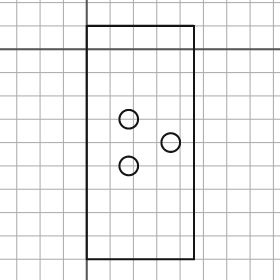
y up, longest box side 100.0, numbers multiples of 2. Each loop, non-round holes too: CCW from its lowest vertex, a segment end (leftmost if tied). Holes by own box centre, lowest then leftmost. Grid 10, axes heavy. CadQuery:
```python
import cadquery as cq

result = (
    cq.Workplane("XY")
    .moveTo(0.0, -90.0)
    .lineTo(46.0, -90.0)
    .lineTo(46.0, 10.0)
    .lineTo(0.0, 10.0)
    .close()
    .moveTo(18.0, -50.0)
    .circle(4.0)
    .moveTo(36.0, -40.0)
    .circle(4.0)
    .moveTo(18.0, -30.0)
    .circle(4.0)
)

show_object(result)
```